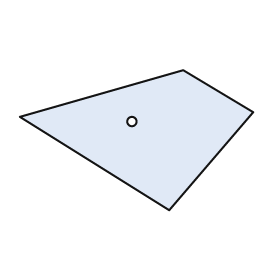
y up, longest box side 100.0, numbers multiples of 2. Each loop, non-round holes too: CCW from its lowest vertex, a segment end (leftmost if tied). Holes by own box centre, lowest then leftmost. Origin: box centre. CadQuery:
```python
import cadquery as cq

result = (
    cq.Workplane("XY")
    .moveTo(14.0, -30.0)
    .lineTo(50.0, 12.0)
    .lineTo(20.0, 30.0)
    .lineTo(-50.0, 10.0)
    .close()
    .moveTo(-2.0, 8.0)
    .circle(2.0)
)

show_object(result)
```